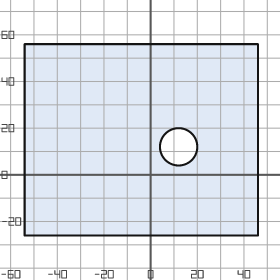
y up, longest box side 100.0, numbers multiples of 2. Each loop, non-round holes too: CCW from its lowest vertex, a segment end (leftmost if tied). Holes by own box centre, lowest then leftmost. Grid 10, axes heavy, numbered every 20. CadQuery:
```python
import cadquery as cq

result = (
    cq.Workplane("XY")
    .moveTo(-54.0, -26.0)
    .lineTo(46.0, -26.0)
    .lineTo(46.0, 56.0)
    .lineTo(-54.0, 56.0)
    .close()
    .moveTo(12.0, 12.0)
    .circle(8.0)
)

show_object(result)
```